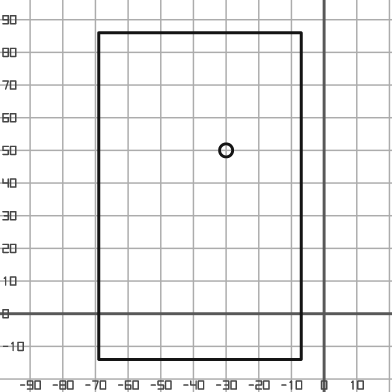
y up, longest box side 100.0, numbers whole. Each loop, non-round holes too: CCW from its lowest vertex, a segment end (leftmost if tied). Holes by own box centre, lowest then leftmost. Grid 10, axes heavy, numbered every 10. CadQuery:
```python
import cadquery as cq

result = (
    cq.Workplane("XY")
    .moveTo(-69.0, -14.0)
    .lineTo(-7.0, -14.0)
    .lineTo(-7.0, 86.0)
    .lineTo(-69.0, 86.0)
    .close()
    .moveTo(-30.0, 50.0)
    .circle(2.0)
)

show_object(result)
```